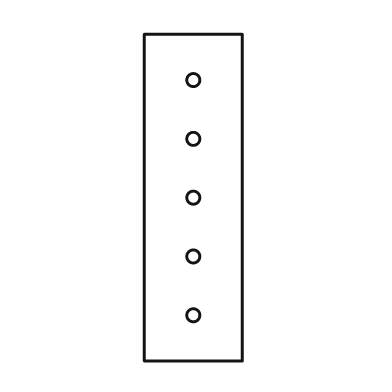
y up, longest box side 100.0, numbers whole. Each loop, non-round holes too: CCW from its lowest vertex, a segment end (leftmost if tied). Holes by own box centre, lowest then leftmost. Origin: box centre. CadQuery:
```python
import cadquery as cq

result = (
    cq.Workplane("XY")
    .moveTo(-15.0, -50.0)
    .lineTo(15.0, -50.0)
    .lineTo(15.0, 50.0)
    .lineTo(-15.0, 50.0)
    .close()
    .moveTo(0.0, -36.0)
    .circle(2.0)
    .moveTo(0.0, -18.0)
    .circle(2.0)
    .moveTo(0.0, 0.0)
    .circle(2.0)
    .moveTo(0.0, 18.0)
    .circle(2.0)
    .moveTo(0.0, 36.0)
    .circle(2.0)
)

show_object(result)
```